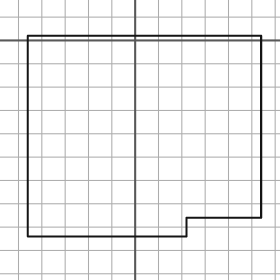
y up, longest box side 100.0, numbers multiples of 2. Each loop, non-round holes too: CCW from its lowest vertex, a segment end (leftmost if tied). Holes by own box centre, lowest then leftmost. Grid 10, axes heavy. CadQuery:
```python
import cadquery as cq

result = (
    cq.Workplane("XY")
    .moveTo(-46.0, -84.0)
    .lineTo(22.0, -84.0)
    .lineTo(22.0, -76.0)
    .lineTo(54.0, -76.0)
    .lineTo(54.0, 2.0)
    .lineTo(-46.0, 2.0)
    .close()
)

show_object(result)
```